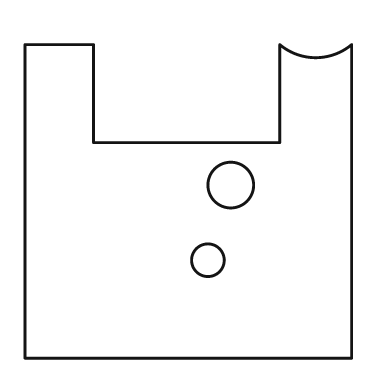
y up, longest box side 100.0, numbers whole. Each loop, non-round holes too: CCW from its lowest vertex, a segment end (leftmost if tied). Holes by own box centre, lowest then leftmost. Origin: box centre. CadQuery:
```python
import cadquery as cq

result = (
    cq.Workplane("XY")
    .moveTo(-50.0, -48.0)
    .lineTo(50.0, -48.0)
    .lineTo(50.0, 48.0)
    .threePointArc((39.0, 44.0), (28.0, 48.0))
    .lineTo(28.0, 18.0)
    .lineTo(-29.0, 18.0)
    .lineTo(-29.0, 48.0)
    .lineTo(-50.0, 48.0)
    .close()
    .moveTo(6.0, -18.0)
    .circle(5.0)
    .moveTo(13.0, 5.0)
    .circle(7.0)
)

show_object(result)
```